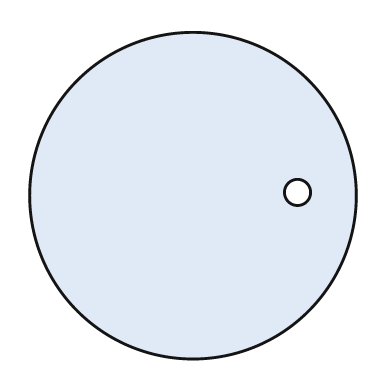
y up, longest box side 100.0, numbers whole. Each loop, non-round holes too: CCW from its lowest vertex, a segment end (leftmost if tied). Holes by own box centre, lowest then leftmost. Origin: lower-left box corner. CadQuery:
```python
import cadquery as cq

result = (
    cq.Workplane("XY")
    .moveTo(50.0, 50.0)
    .circle(50.0)
    .moveTo(82.0, 51.0)
    .circle(4.0)
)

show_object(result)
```